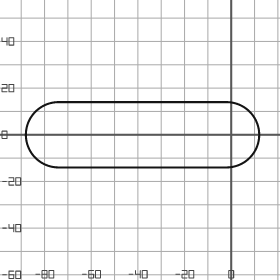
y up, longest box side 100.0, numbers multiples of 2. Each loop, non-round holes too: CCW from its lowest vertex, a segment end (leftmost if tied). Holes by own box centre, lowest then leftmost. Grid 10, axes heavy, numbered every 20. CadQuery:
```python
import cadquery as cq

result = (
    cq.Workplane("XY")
    .moveTo(-74.0, -14.0)
    .lineTo(-2.0, -14.0)
    .threePointArc((12.0, 0.0), (-2.0, 14.0))
    .lineTo(-74.0, 14.0)
    .threePointArc((-88.0, 0.0), (-74.0, -14.0))
    .close()
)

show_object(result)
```